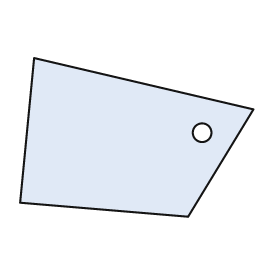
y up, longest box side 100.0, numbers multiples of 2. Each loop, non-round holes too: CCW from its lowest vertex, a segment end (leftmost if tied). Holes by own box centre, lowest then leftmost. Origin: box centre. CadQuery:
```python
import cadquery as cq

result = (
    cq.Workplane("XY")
    .moveTo(22.0, -34.0)
    .lineTo(50.0, 12.0)
    .lineTo(-44.0, 34.0)
    .lineTo(-50.0, -28.0)
    .close()
    .moveTo(28.0, 2.0)
    .circle(4.0)
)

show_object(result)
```